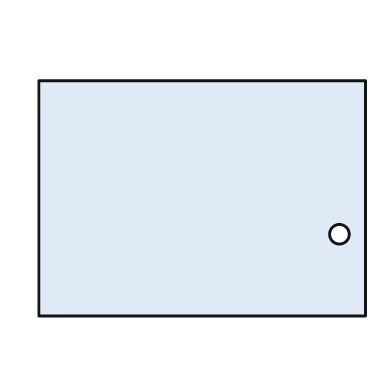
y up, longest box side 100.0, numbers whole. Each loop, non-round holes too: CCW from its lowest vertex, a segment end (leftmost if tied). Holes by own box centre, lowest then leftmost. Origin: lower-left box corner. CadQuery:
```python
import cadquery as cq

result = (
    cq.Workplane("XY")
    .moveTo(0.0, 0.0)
    .lineTo(100.0, 0.0)
    .lineTo(100.0, 72.0)
    .lineTo(0.0, 72.0)
    .close()
    .moveTo(92.0, 25.0)
    .circle(3.0)
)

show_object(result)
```